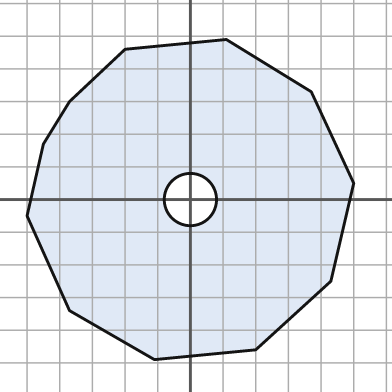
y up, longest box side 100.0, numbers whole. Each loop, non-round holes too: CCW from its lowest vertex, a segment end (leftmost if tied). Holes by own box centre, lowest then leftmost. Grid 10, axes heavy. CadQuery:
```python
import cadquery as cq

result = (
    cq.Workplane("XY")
    .moveTo(-11.0, -49.0)
    .lineTo(20.0, -46.0)
    .lineTo(43.0, -25.0)
    .lineTo(50.0, 5.0)
    .lineTo(37.0, 33.0)
    .lineTo(11.0, 49.0)
    .lineTo(-20.0, 46.0)
    .lineTo(-37.0, 30.0)
    .lineTo(-45.0, 17.0)
    .lineTo(-50.0, -5.0)
    .lineTo(-37.0, -34.0)
    .close()
    .moveTo(0.0, 0.0)
    .circle(8.0)
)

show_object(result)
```